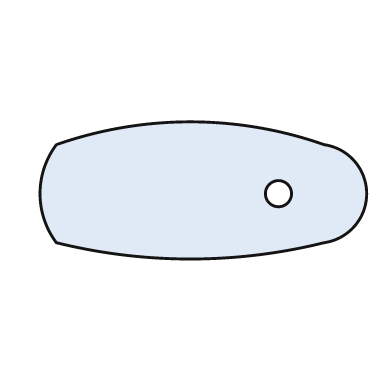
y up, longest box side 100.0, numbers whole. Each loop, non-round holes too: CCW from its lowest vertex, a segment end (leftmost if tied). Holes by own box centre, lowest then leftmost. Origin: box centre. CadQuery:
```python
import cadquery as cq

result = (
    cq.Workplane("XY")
    .moveTo(-45.0, -16.0)
    .threePointArc((-4.0, -21.0), (37.0, -16.0))
    .threePointArc((50.0, -1.0), (37.0, 14.0))
    .threePointArc((-4.0, 21.0), (-45.0, 14.0))
    .threePointArc((-50.0, -1.0), (-45.0, -16.0))
    .close()
    .moveTo(23.0, -1.0)
    .circle(4.0)
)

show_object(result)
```